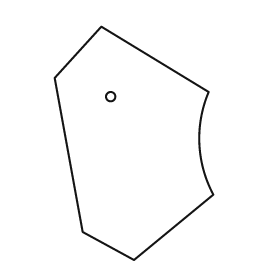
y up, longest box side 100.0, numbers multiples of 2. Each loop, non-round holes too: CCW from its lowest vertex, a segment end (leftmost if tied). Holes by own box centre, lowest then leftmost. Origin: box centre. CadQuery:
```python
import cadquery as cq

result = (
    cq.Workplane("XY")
    .moveTo(0.0, -50.0)
    .lineTo(34.0, -22.0)
    .threePointArc((28.0, 0.0), (32.0, 22.0))
    .lineTo(-14.0, 50.0)
    .lineTo(-34.0, 28.0)
    .lineTo(-22.0, -38.0)
    .close()
    .moveTo(-10.0, 20.0)
    .circle(2.0)
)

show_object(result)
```